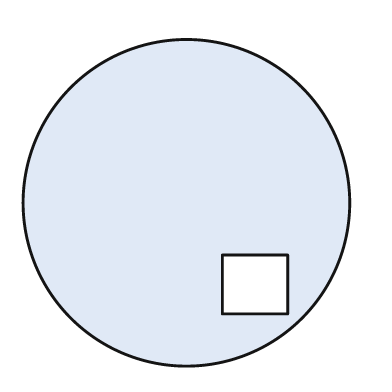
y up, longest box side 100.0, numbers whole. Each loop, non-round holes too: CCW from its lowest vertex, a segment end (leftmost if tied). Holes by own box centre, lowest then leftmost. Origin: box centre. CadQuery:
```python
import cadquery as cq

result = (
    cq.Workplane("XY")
    .moveTo(0.0, 0.0)
    .circle(50.0)
    .moveTo(11.0, -34.0)
    .lineTo(31.0, -34.0)
    .lineTo(31.0, -16.0)
    .lineTo(11.0, -16.0)
    .close()
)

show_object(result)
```